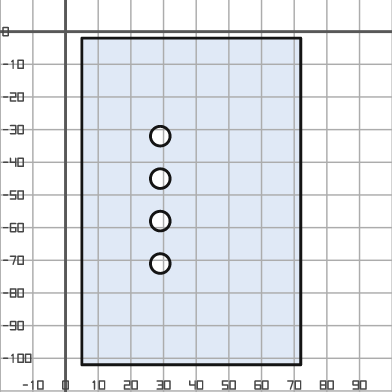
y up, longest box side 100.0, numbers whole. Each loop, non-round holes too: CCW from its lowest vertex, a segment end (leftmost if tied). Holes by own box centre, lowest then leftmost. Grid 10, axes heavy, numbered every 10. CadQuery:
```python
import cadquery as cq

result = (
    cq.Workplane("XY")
    .moveTo(5.0, -102.0)
    .lineTo(72.0, -102.0)
    .lineTo(72.0, -2.0)
    .lineTo(5.0, -2.0)
    .close()
    .moveTo(29.0, -71.0)
    .circle(3.0)
    .moveTo(29.0, -58.0)
    .circle(3.0)
    .moveTo(29.0, -45.0)
    .circle(3.0)
    .moveTo(29.0, -32.0)
    .circle(3.0)
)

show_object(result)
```